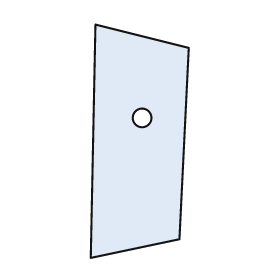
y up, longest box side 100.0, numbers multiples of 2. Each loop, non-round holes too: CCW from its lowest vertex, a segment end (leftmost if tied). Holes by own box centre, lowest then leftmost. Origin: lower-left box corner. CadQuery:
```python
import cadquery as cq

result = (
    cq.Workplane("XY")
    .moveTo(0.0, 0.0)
    .lineTo(38.0, 8.0)
    .lineTo(42.0, 90.0)
    .lineTo(2.0, 100.0)
    .close()
    .moveTo(22.0, 60.0)
    .circle(4.0)
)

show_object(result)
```